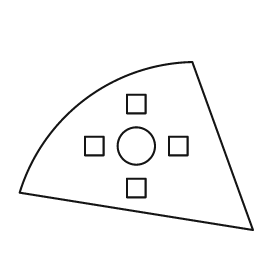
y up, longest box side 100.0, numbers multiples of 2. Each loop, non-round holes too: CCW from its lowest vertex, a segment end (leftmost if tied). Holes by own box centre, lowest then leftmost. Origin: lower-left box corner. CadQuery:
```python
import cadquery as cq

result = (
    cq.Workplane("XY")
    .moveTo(100.0, 0.0)
    .lineTo(74.0, 72.0)
    .threePointArc((28.0, 56.0), (0.0, 16.0))
    .close()
    .moveTo(46.0, 14.0)
    .lineTo(54.0, 14.0)
    .lineTo(54.0, 22.0)
    .lineTo(46.0, 22.0)
    .close()
    .moveTo(28.0, 32.0)
    .lineTo(36.0, 32.0)
    .lineTo(36.0, 40.0)
    .lineTo(28.0, 40.0)
    .close()
    .moveTo(50.0, 36.0)
    .circle(8.0)
    .moveTo(64.0, 32.0)
    .lineTo(72.0, 32.0)
    .lineTo(72.0, 40.0)
    .lineTo(64.0, 40.0)
    .close()
    .moveTo(46.0, 50.0)
    .lineTo(54.0, 50.0)
    .lineTo(54.0, 58.0)
    .lineTo(46.0, 58.0)
    .close()
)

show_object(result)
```